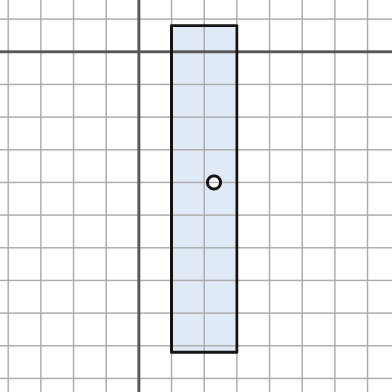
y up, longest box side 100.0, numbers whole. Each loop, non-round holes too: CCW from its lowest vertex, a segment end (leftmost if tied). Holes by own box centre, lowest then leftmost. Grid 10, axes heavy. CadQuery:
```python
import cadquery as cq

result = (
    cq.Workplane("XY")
    .moveTo(10.0, -92.0)
    .lineTo(30.0, -92.0)
    .lineTo(30.0, 8.0)
    .lineTo(10.0, 8.0)
    .close()
    .moveTo(23.0, -40.0)
    .circle(2.0)
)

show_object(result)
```